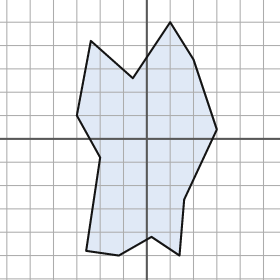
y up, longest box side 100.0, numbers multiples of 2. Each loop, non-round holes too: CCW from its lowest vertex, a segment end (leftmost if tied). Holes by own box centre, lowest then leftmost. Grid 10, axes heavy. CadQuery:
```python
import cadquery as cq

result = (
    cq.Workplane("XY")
    .moveTo(-12.0, -50.0)
    .lineTo(2.0, -42.0)
    .lineTo(14.0, -50.0)
    .lineTo(16.0, -26.0)
    .lineTo(30.0, 4.0)
    .lineTo(20.0, 34.0)
    .lineTo(10.0, 50.0)
    .lineTo(-6.0, 26.0)
    .lineTo(-24.0, 42.0)
    .lineTo(-30.0, 10.0)
    .lineTo(-20.0, -8.0)
    .lineTo(-26.0, -48.0)
    .close()
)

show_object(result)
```